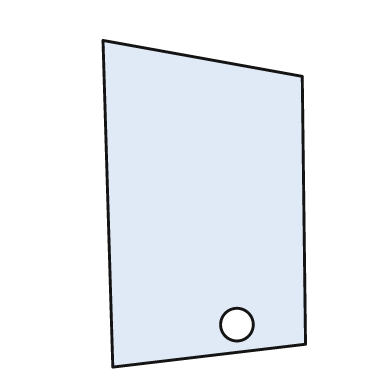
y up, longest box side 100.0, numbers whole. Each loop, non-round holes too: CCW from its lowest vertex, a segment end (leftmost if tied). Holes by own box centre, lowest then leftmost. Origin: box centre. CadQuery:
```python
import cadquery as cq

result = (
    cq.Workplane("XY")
    .moveTo(-28.0, -50.0)
    .lineTo(31.0, -43.0)
    .lineTo(30.0, 39.0)
    .lineTo(-31.0, 50.0)
    .close()
    .moveTo(10.0, -37.0)
    .circle(5.0)
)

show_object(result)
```